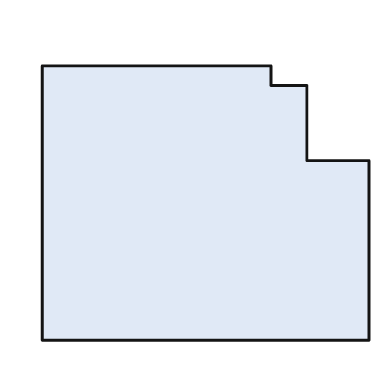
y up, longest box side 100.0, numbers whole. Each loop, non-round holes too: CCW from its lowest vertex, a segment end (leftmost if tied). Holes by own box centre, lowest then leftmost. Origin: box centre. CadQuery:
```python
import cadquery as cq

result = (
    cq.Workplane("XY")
    .moveTo(-50.0, -42.0)
    .lineTo(50.0, -42.0)
    .lineTo(50.0, 13.0)
    .lineTo(31.0, 13.0)
    .lineTo(31.0, 36.0)
    .lineTo(20.0, 36.0)
    .lineTo(20.0, 42.0)
    .lineTo(-50.0, 42.0)
    .close()
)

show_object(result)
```